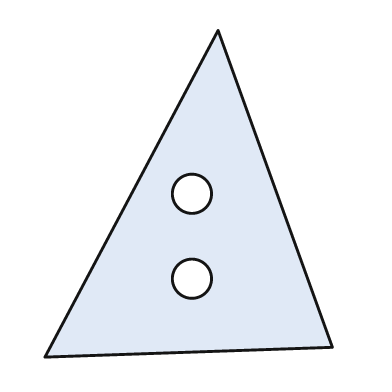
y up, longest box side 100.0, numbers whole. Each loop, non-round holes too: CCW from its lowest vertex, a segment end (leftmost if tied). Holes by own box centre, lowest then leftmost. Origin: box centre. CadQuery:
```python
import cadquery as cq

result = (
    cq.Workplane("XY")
    .moveTo(-44.0, -50.0)
    .lineTo(44.0, -47.0)
    .lineTo(9.0, 50.0)
    .close()
    .moveTo(1.0, -26.0)
    .circle(6.0)
    .moveTo(1.0, 0.0)
    .circle(6.0)
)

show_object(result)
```